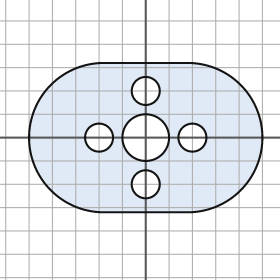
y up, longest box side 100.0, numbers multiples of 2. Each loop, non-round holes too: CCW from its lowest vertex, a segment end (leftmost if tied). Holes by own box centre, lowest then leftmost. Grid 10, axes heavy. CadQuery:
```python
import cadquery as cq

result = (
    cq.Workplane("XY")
    .moveTo(-18.0, -32.0)
    .lineTo(18.0, -32.0)
    .threePointArc((50.0, 0.0), (18.0, 32.0))
    .lineTo(-18.0, 32.0)
    .threePointArc((-50.0, 0.0), (-18.0, -32.0))
    .close()
    .moveTo(0.0, -20.0)
    .circle(6.0)
    .moveTo(-20.0, 0.0)
    .circle(6.0)
    .moveTo(0.0, 0.0)
    .circle(10.0)
    .moveTo(20.0, 0.0)
    .circle(6.0)
    .moveTo(0.0, 20.0)
    .circle(6.0)
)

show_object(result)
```